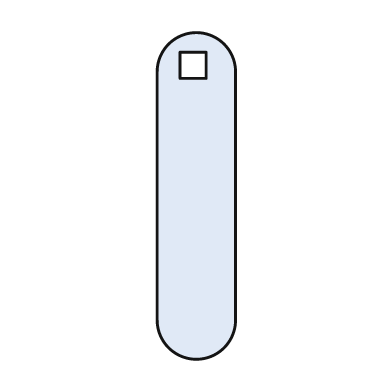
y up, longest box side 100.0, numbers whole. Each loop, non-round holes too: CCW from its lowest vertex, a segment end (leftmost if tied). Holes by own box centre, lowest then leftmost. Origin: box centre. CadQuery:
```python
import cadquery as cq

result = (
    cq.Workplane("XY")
    .moveTo(-12.0, -38.0)
    .threePointArc((0.0, -50.0), (12.0, -38.0))
    .lineTo(12.0, 38.0)
    .threePointArc((0.0, 50.0), (-12.0, 38.0))
    .close()
    .moveTo(-5.0, 36.0)
    .lineTo(3.0, 36.0)
    .lineTo(3.0, 44.0)
    .lineTo(-5.0, 44.0)
    .close()
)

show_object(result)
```